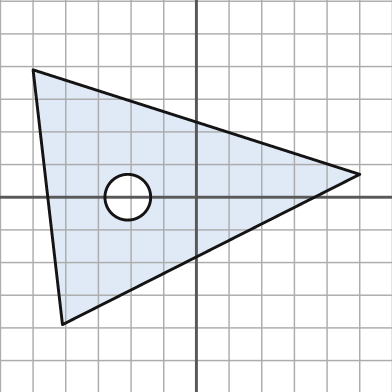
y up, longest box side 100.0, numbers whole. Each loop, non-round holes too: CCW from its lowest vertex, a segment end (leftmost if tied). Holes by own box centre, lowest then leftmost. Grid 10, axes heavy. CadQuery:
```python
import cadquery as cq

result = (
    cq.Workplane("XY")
    .moveTo(-41.0, -39.0)
    .lineTo(50.0, 7.0)
    .lineTo(-50.0, 39.0)
    .close()
    .moveTo(-21.0, 0.0)
    .circle(7.0)
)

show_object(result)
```